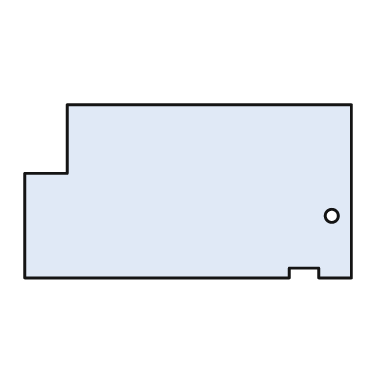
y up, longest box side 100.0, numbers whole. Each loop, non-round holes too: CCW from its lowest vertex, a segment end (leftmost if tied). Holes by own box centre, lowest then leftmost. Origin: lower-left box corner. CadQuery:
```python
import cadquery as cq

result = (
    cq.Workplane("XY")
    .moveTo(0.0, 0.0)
    .lineTo(81.0, 0.0)
    .lineTo(81.0, 3.0)
    .lineTo(90.0, 3.0)
    .lineTo(90.0, 0.0)
    .lineTo(100.0, 0.0)
    .lineTo(100.0, 53.0)
    .lineTo(13.0, 53.0)
    .lineTo(13.0, 32.0)
    .lineTo(0.0, 32.0)
    .close()
    .moveTo(94.0, 19.0)
    .circle(2.0)
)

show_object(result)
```